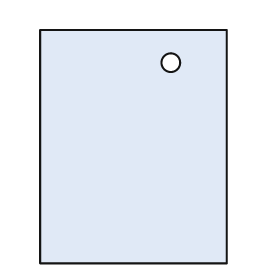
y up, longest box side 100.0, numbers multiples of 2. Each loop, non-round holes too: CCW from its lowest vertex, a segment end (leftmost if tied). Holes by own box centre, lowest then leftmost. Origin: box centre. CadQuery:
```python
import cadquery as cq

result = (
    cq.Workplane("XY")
    .moveTo(-40.0, -50.0)
    .lineTo(40.0, -50.0)
    .lineTo(40.0, 50.0)
    .lineTo(-40.0, 50.0)
    .close()
    .moveTo(16.0, 36.0)
    .circle(4.0)
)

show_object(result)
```